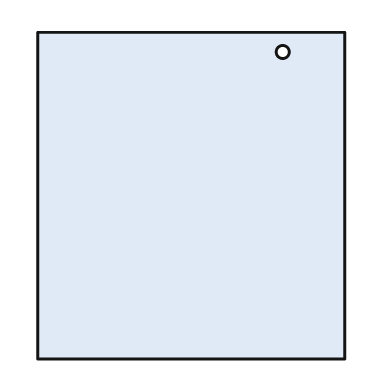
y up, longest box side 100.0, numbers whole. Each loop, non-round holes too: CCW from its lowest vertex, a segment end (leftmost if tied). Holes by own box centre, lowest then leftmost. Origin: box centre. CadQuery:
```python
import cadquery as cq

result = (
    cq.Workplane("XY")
    .moveTo(-47.0, -50.0)
    .lineTo(47.0, -50.0)
    .lineTo(47.0, 50.0)
    .lineTo(-47.0, 50.0)
    .close()
    .moveTo(28.0, 44.0)
    .circle(2.0)
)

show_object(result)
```